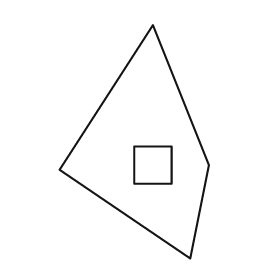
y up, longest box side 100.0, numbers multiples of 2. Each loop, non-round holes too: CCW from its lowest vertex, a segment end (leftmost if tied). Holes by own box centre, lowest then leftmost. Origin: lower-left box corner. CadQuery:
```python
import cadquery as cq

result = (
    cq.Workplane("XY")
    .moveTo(56.0, 0.0)
    .lineTo(64.0, 40.0)
    .lineTo(40.0, 100.0)
    .lineTo(0.0, 38.0)
    .close()
    .moveTo(32.0, 32.0)
    .lineTo(48.0, 32.0)
    .lineTo(48.0, 48.0)
    .lineTo(32.0, 48.0)
    .close()
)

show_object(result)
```